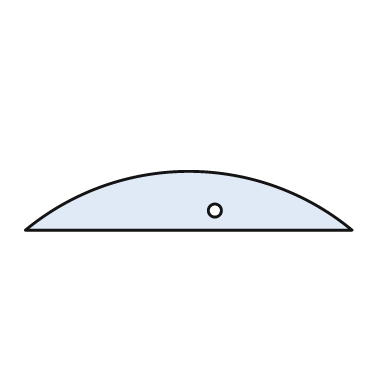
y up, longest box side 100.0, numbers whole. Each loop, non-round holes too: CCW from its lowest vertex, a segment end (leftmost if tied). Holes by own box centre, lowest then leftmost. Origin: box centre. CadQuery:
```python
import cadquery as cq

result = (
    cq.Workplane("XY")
    .moveTo(-50.0, -9.0)
    .lineTo(50.0, -9.0)
    .threePointArc((0.0, 9.0), (-50.0, -9.0))
    .close()
    .moveTo(8.0, -3.0)
    .circle(2.0)
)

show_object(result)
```